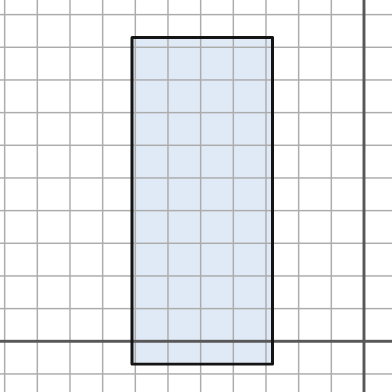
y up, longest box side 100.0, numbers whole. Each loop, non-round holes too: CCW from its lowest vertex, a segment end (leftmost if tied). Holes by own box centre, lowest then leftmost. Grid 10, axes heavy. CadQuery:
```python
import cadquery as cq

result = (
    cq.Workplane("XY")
    .moveTo(-71.0, -7.0)
    .lineTo(-28.0, -7.0)
    .lineTo(-28.0, 93.0)
    .lineTo(-71.0, 93.0)
    .close()
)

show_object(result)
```